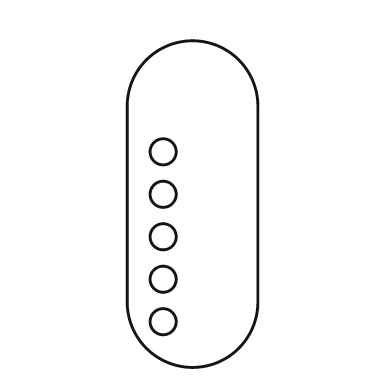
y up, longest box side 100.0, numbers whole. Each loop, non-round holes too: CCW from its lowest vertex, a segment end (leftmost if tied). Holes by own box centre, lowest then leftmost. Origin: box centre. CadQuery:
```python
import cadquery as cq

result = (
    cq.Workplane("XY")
    .moveTo(-20.0, -30.0)
    .threePointArc((0.0, -50.0), (20.0, -30.0))
    .lineTo(20.0, 30.0)
    .threePointArc((0.0, 50.0), (-20.0, 30.0))
    .close()
    .moveTo(-9.0, -36.0)
    .circle(4.0)
    .moveTo(-9.0, -23.0)
    .circle(4.0)
    .moveTo(-9.0, -10.0)
    .circle(4.0)
    .moveTo(-9.0, 3.0)
    .circle(4.0)
    .moveTo(-9.0, 16.0)
    .circle(4.0)
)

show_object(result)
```